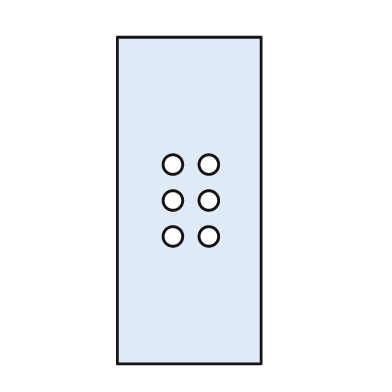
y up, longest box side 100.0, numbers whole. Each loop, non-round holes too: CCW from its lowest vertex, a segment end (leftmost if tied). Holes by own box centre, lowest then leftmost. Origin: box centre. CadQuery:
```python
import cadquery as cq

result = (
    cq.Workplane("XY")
    .moveTo(-22.0, -50.0)
    .lineTo(22.0, -50.0)
    .lineTo(22.0, 50.0)
    .lineTo(-22.0, 50.0)
    .close()
    .moveTo(-5.0, -11.0)
    .circle(3.0)
    .moveTo(6.0, -11.0)
    .circle(3.0)
    .moveTo(-5.0, 0.0)
    .circle(3.0)
    .moveTo(6.0, 0.0)
    .circle(3.0)
    .moveTo(-5.0, 11.0)
    .circle(3.0)
    .moveTo(6.0, 11.0)
    .circle(3.0)
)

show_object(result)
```